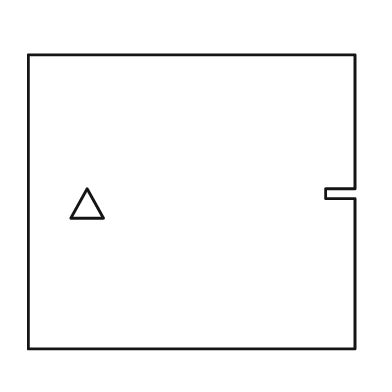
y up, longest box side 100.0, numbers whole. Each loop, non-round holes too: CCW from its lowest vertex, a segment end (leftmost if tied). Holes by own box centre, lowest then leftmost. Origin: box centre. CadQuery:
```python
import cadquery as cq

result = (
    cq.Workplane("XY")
    .moveTo(-50.0, -45.0)
    .lineTo(50.0, -45.0)
    .lineTo(50.0, 1.0)
    .lineTo(41.0, 1.0)
    .lineTo(41.0, 4.0)
    .lineTo(50.0, 4.0)
    .lineTo(50.0, 45.0)
    .lineTo(-50.0, 45.0)
    .close()
    .moveTo(-37.0, -5.0)
    .lineTo(-27.0, -5.0)
    .lineTo(-32.0, 4.0)
    .close()
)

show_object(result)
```